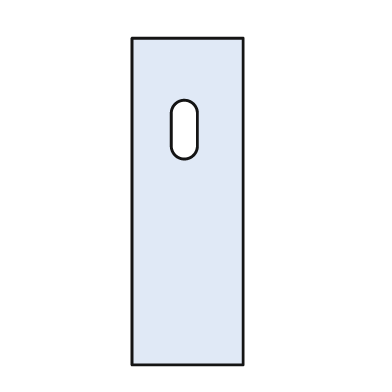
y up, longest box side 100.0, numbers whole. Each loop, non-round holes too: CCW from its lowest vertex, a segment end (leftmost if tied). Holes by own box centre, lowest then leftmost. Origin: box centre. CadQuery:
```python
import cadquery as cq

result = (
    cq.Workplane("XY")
    .moveTo(-17.0, -50.0)
    .lineTo(17.0, -50.0)
    .lineTo(17.0, 50.0)
    .lineTo(-17.0, 50.0)
    .close()
    .moveTo(-5.0, 17.0)
    .threePointArc((-1.0, 13.0), (3.0, 17.0))
    .lineTo(3.0, 27.0)
    .threePointArc((-1.0, 31.0), (-5.0, 27.0))
    .close()
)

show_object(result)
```